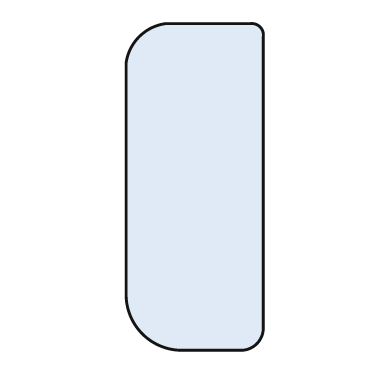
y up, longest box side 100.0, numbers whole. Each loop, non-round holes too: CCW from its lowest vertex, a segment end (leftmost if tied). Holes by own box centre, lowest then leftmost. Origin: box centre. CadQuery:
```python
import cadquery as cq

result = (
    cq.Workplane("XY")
    .moveTo(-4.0, -50.0)
    .lineTo(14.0, -50.0)
    .threePointArc((19.0, -48.0), (21.0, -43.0))
    .lineTo(21.0, 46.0)
    .threePointArc((20.0, 49.0), (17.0, 50.0))
    .lineTo(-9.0, 50.0)
    .threePointArc((-17.0, 46.0), (-21.0, 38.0))
    .lineTo(-21.0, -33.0)
    .threePointArc((-16.0, -45.0), (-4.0, -50.0))
    .close()
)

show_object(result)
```